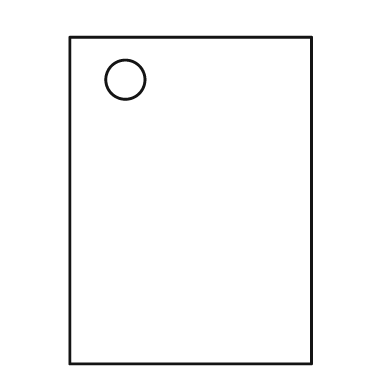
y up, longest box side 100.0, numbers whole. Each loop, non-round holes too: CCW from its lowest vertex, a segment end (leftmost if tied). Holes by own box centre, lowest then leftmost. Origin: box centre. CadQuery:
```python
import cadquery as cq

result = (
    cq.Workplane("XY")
    .moveTo(-37.0, -50.0)
    .lineTo(37.0, -50.0)
    .lineTo(37.0, 50.0)
    .lineTo(-37.0, 50.0)
    .close()
    .moveTo(-20.0, 37.0)
    .circle(6.0)
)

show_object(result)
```